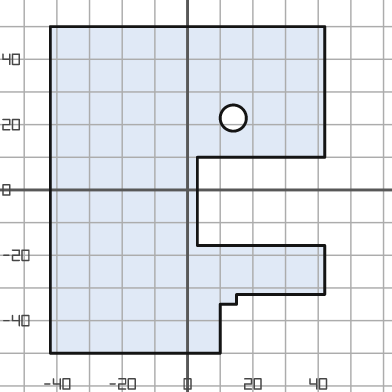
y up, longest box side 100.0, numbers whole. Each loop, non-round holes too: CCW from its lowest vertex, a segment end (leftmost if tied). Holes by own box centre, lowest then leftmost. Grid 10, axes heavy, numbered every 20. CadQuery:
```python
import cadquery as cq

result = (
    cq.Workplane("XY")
    .moveTo(-42.0, -50.0)
    .lineTo(10.0, -50.0)
    .lineTo(10.0, -35.0)
    .lineTo(15.0, -35.0)
    .lineTo(15.0, -32.0)
    .lineTo(42.0, -32.0)
    .lineTo(42.0, -17.0)
    .lineTo(3.0, -17.0)
    .lineTo(3.0, 10.0)
    .lineTo(42.0, 10.0)
    .lineTo(42.0, 50.0)
    .lineTo(-42.0, 50.0)
    .close()
    .moveTo(14.0, 22.0)
    .circle(4.0)
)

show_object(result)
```